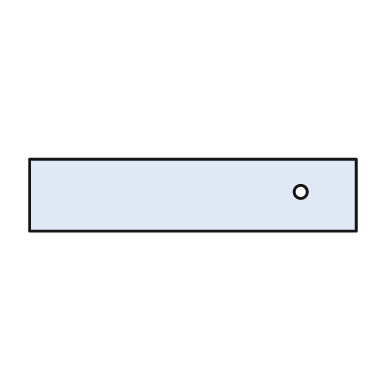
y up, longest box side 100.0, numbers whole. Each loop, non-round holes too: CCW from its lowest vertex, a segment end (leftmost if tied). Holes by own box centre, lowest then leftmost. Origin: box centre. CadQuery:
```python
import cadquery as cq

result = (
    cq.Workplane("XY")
    .moveTo(-50.0, -11.0)
    .lineTo(50.0, -11.0)
    .lineTo(50.0, 11.0)
    .lineTo(-50.0, 11.0)
    .close()
    .moveTo(33.0, 1.0)
    .circle(2.0)
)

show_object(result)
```